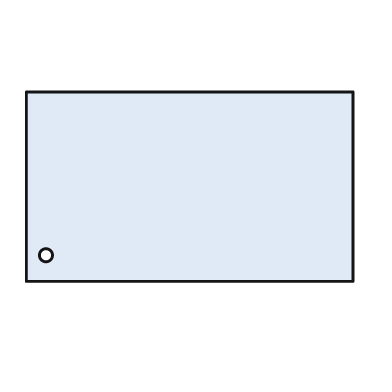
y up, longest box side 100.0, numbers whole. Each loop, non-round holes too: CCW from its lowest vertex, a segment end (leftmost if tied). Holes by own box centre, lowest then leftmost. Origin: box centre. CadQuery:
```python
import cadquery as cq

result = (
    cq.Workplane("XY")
    .moveTo(-50.0, -29.0)
    .lineTo(50.0, -29.0)
    .lineTo(50.0, 29.0)
    .lineTo(-50.0, 29.0)
    .close()
    .moveTo(-44.0, -21.0)
    .circle(2.0)
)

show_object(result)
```